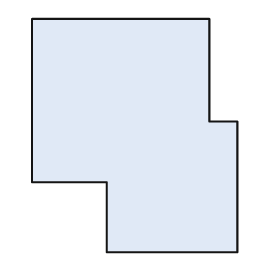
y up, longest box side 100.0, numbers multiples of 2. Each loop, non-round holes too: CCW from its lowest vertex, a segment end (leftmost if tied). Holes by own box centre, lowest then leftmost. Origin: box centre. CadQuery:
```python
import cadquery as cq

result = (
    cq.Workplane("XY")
    .moveTo(-12.0, -50.0)
    .lineTo(44.0, -50.0)
    .lineTo(44.0, 6.0)
    .lineTo(32.0, 6.0)
    .lineTo(32.0, 50.0)
    .lineTo(-44.0, 50.0)
    .lineTo(-44.0, -20.0)
    .lineTo(-12.0, -20.0)
    .close()
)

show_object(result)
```